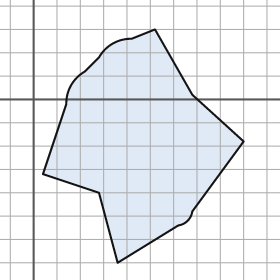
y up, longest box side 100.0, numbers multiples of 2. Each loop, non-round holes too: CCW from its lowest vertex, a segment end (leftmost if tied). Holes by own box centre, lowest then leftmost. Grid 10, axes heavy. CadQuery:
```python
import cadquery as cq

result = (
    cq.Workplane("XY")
    .moveTo(36.0, -70.0)
    .lineTo(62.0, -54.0)
    .threePointArc((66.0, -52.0), (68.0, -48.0))
    .lineTo(90.0, -18.0)
    .lineTo(68.0, 2.0)
    .lineTo(52.0, 30.0)
    .lineTo(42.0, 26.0)
    .threePointArc((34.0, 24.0), (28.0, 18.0))
    .lineTo(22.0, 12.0)
    .threePointArc((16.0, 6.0), (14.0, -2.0))
    .lineTo(4.0, -32.0)
    .lineTo(28.0, -40.0)
    .close()
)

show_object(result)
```